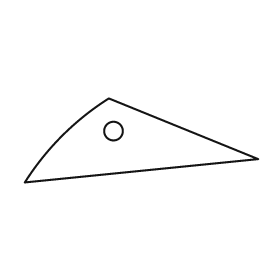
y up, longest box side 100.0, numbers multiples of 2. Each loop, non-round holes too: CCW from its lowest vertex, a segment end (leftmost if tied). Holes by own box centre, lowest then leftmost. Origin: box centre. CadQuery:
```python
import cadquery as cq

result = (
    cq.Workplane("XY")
    .moveTo(-50.0, -18.0)
    .lineTo(50.0, -8.0)
    .lineTo(-14.0, 18.0)
    .threePointArc((-34.0, 2.0), (-50.0, -18.0))
    .close()
    .moveTo(-12.0, 4.0)
    .circle(4.0)
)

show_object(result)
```